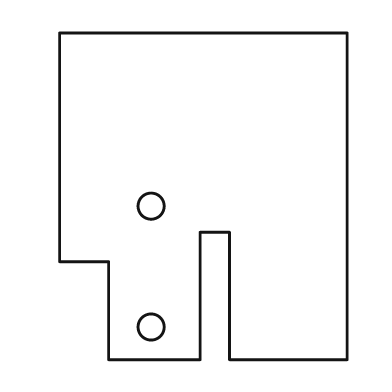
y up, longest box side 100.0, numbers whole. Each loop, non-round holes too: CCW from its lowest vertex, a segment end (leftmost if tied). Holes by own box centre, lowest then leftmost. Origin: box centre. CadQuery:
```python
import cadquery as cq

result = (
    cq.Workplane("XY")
    .moveTo(-29.0, -50.0)
    .lineTo(-1.0, -50.0)
    .lineTo(-1.0, -11.0)
    .lineTo(8.0, -11.0)
    .lineTo(8.0, -50.0)
    .lineTo(44.0, -50.0)
    .lineTo(44.0, 50.0)
    .lineTo(-44.0, 50.0)
    .lineTo(-44.0, -20.0)
    .lineTo(-29.0, -20.0)
    .close()
    .moveTo(-16.0, -40.0)
    .circle(4.0)
    .moveTo(-16.0, -3.0)
    .circle(4.0)
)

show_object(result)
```